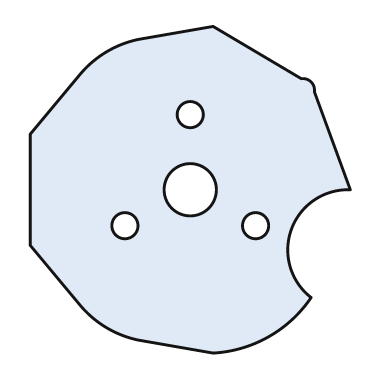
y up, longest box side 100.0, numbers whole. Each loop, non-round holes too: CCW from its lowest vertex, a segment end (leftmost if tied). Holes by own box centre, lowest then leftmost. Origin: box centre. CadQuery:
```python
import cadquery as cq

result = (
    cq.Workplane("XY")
    .moveTo(7.0, -50.0)
    .threePointArc((24.0, -45.0), (37.0, -33.0))
    .threePointArc((31.0, -12.0), (49.0, 0.0))
    .lineTo(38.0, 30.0)
    .threePointArc((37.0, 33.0), (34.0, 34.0))
    .lineTo(7.0, 50.0)
    .lineTo(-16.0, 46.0)
    .threePointArc((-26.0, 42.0), (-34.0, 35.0))
    .lineTo(-49.0, 17.0)
    .lineTo(-49.0, -17.0)
    .lineTo(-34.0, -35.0)
    .threePointArc((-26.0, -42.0), (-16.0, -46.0))
    .close()
    .moveTo(-20.0, -11.0)
    .circle(4.0)
    .moveTo(20.0, -11.0)
    .circle(4.0)
    .moveTo(0.0, 0.0)
    .circle(8.0)
    .moveTo(0.0, 23.0)
    .circle(4.0)
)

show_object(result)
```